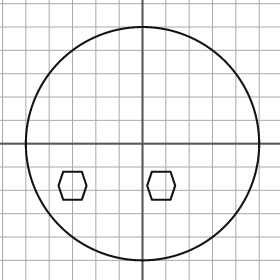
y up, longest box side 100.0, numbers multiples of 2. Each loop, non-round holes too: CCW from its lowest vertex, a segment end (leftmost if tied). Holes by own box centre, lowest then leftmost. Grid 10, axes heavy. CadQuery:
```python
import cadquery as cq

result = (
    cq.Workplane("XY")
    .moveTo(0.0, 0.0)
    .circle(50.0)
    .moveTo(-34.0, -24.0)
    .lineTo(-26.0, -24.0)
    .lineTo(-24.0, -18.0)
    .lineTo(-26.0, -12.0)
    .lineTo(-34.0, -12.0)
    .lineTo(-36.0, -18.0)
    .close()
    .moveTo(4.0, -24.0)
    .lineTo(12.0, -24.0)
    .lineTo(14.0, -18.0)
    .lineTo(12.0, -12.0)
    .lineTo(4.0, -12.0)
    .lineTo(2.0, -18.0)
    .close()
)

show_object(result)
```